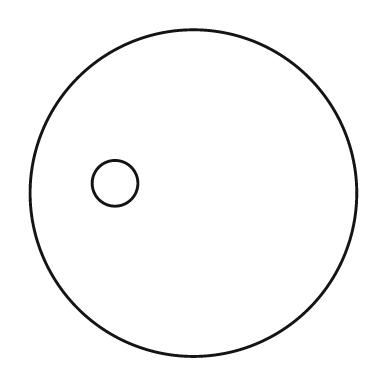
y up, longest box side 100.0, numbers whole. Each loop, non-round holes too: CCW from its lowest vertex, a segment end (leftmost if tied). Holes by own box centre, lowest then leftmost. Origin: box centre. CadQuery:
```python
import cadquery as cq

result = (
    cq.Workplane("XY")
    .moveTo(0.0, 0.0)
    .circle(50.0)
    .moveTo(-24.0, 3.0)
    .circle(7.0)
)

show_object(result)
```